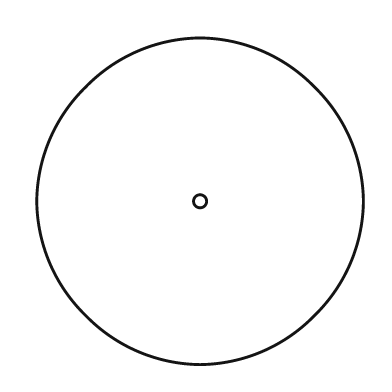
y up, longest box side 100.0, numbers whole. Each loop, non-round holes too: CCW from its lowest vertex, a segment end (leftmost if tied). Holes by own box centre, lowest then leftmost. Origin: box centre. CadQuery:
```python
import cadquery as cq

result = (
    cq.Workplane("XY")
    .moveTo(0.0, -50.0)
    .threePointArc((19.0, -46.0), (35.0, -35.0))
    .threePointArc((46.0, -19.0), (50.0, 0.0))
    .threePointArc((46.0, 19.0), (35.0, 35.0))
    .threePointArc((19.0, 46.0), (0.0, 50.0))
    .threePointArc((-19.0, 46.0), (-35.0, 35.0))
    .threePointArc((-46.0, 19.0), (-50.0, 0.0))
    .threePointArc((-46.0, -19.0), (-35.0, -35.0))
    .threePointArc((-19.0, -46.0), (0.0, -50.0))
    .close()
    .moveTo(0.0, 0.0)
    .circle(2.0)
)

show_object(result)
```